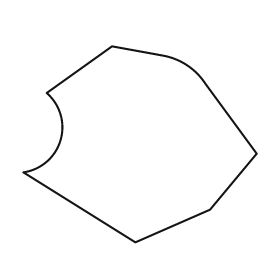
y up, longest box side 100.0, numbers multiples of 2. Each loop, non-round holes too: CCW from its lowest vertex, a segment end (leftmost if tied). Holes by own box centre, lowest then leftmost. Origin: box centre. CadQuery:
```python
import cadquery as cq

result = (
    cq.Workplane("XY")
    .moveTo(-2.0, -42.0)
    .lineTo(30.0, -28.0)
    .lineTo(50.0, -4.0)
    .lineTo(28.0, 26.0)
    .threePointArc((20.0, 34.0), (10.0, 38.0))
    .lineTo(-12.0, 42.0)
    .lineTo(-40.0, 22.0)
    .threePointArc((-34.0, 2.0), (-50.0, -12.0))
    .close()
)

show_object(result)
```